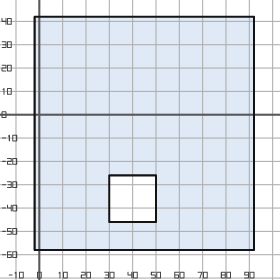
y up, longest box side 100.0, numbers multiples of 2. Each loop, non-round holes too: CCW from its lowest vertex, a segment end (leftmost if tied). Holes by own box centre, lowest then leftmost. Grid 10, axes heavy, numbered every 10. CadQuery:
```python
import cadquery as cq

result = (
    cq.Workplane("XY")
    .moveTo(-2.0, -58.0)
    .lineTo(92.0, -58.0)
    .lineTo(92.0, 42.0)
    .lineTo(-2.0, 42.0)
    .close()
    .moveTo(30.0, -46.0)
    .lineTo(50.0, -46.0)
    .lineTo(50.0, -26.0)
    .lineTo(30.0, -26.0)
    .close()
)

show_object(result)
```